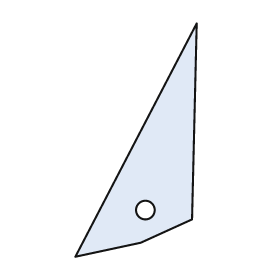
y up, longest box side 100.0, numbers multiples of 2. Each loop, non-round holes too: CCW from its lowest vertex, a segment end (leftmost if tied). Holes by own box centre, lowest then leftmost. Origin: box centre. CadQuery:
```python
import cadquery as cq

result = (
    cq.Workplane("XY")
    .moveTo(-26.0, -50.0)
    .lineTo(2.0, -44.0)
    .lineTo(24.0, -34.0)
    .lineTo(26.0, 50.0)
    .close()
    .moveTo(4.0, -30.0)
    .circle(4.0)
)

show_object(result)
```